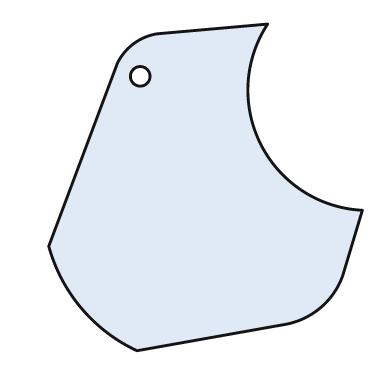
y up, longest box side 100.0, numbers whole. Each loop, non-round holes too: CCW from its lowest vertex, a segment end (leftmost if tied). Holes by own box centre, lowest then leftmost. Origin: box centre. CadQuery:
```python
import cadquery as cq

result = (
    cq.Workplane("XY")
    .moveTo(-21.0, -50.0)
    .lineTo(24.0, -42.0)
    .threePointArc((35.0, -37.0), (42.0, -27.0))
    .lineTo(48.0, -7.0)
    .threePointArc((17.0, 13.0), (19.0, 50.0))
    .lineTo(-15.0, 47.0)
    .threePointArc((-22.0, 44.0), (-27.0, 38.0))
    .lineTo(-48.0, -18.0)
    .threePointArc((-38.0, -37.0), (-21.0, -50.0))
    .close()
    .moveTo(-20.0, 34.0)
    .circle(3.0)
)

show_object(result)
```